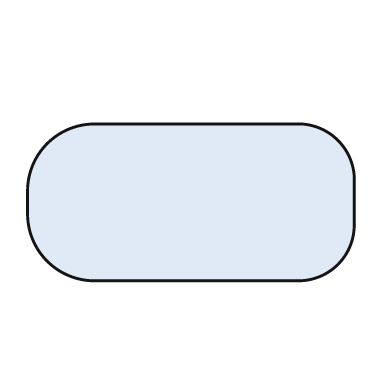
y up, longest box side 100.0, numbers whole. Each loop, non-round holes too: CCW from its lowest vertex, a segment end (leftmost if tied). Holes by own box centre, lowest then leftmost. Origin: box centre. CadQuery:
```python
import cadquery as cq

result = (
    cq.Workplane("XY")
    .moveTo(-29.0, -24.0)
    .lineTo(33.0, -24.0)
    .threePointArc((45.0, -19.0), (50.0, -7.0))
    .lineTo(50.0, 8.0)
    .threePointArc((45.0, 19.0), (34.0, 24.0))
    .lineTo(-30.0, 24.0)
    .threePointArc((-44.0, 18.0), (-50.0, 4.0))
    .lineTo(-50.0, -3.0)
    .threePointArc((-44.0, -18.0), (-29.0, -24.0))
    .close()
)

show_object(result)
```